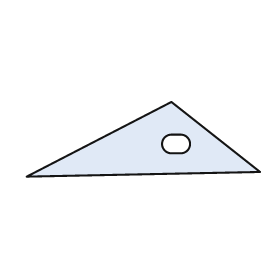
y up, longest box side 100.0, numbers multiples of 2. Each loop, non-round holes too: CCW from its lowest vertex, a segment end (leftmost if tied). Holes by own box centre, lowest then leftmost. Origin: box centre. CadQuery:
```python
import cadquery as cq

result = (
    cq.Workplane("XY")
    .moveTo(-50.0, -16.0)
    .lineTo(50.0, -14.0)
    .lineTo(12.0, 16.0)
    .close()
    .moveTo(12.0, -6.0)
    .lineTo(16.0, -6.0)
    .threePointArc((20.0, -2.0), (16.0, 2.0))
    .lineTo(12.0, 2.0)
    .threePointArc((8.0, -2.0), (12.0, -6.0))
    .close()
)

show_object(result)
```